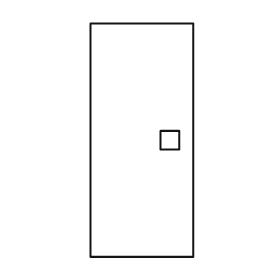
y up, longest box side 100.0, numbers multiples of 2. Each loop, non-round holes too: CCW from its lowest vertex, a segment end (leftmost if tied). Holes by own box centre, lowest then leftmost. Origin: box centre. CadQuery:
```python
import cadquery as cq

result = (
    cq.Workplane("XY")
    .moveTo(-22.0, -50.0)
    .lineTo(22.0, -50.0)
    .lineTo(22.0, 50.0)
    .lineTo(-22.0, 50.0)
    .close()
    .moveTo(8.0, -4.0)
    .lineTo(16.0, -4.0)
    .lineTo(16.0, 4.0)
    .lineTo(8.0, 4.0)
    .close()
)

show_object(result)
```